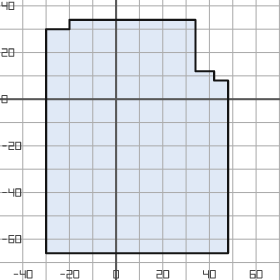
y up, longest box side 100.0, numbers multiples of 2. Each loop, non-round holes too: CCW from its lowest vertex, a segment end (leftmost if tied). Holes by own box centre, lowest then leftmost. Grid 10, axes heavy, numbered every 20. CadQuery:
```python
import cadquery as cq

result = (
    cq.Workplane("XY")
    .moveTo(-30.0, -66.0)
    .lineTo(48.0, -66.0)
    .lineTo(48.0, 8.0)
    .lineTo(42.0, 8.0)
    .lineTo(42.0, 12.0)
    .lineTo(34.0, 12.0)
    .lineTo(34.0, 34.0)
    .lineTo(-20.0, 34.0)
    .lineTo(-20.0, 30.0)
    .lineTo(-30.0, 30.0)
    .close()
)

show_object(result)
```